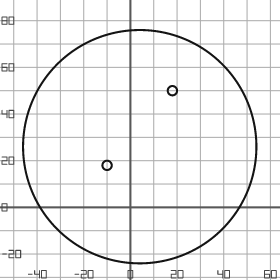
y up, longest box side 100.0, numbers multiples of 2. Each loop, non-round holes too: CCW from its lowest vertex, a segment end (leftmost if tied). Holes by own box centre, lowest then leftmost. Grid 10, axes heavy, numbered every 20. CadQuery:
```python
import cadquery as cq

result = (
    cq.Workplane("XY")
    .moveTo(4.0, 26.0)
    .circle(50.0)
    .moveTo(-10.0, 18.0)
    .circle(2.0)
    .moveTo(18.0, 50.0)
    .circle(2.0)
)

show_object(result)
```